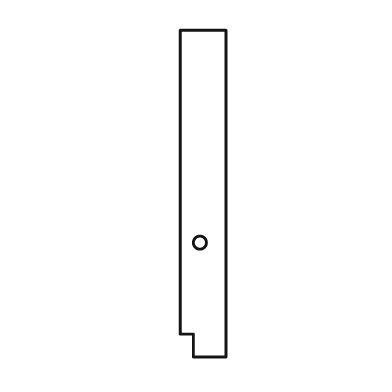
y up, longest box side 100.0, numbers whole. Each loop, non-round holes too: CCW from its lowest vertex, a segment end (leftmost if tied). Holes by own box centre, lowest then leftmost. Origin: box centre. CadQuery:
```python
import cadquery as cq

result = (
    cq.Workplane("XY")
    .moveTo(-3.0, -50.0)
    .lineTo(7.0, -50.0)
    .lineTo(7.0, 50.0)
    .lineTo(-7.0, 50.0)
    .lineTo(-7.0, -43.0)
    .lineTo(-3.0, -43.0)
    .close()
    .moveTo(-1.0, -15.0)
    .circle(2.0)
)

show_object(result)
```